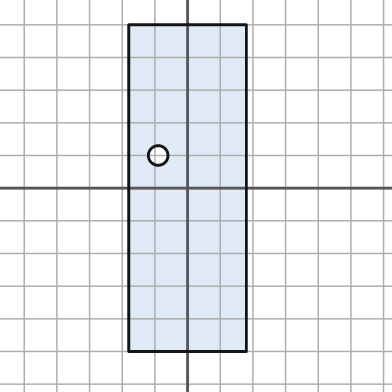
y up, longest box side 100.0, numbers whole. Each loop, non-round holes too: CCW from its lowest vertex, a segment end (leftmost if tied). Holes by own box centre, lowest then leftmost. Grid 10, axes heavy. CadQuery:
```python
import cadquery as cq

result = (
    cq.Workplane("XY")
    .moveTo(-18.0, -50.0)
    .lineTo(18.0, -50.0)
    .lineTo(18.0, 50.0)
    .lineTo(-18.0, 50.0)
    .close()
    .moveTo(-9.0, 10.0)
    .circle(3.0)
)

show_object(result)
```